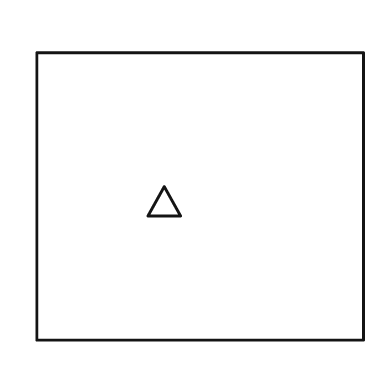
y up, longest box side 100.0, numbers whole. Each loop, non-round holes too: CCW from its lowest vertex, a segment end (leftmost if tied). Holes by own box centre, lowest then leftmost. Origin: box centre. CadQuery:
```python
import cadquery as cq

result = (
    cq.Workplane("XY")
    .moveTo(-50.0, -44.0)
    .lineTo(50.0, -44.0)
    .lineTo(50.0, 44.0)
    .lineTo(-50.0, 44.0)
    .close()
    .moveTo(-16.0, -6.0)
    .lineTo(-6.0, -6.0)
    .lineTo(-11.0, 3.0)
    .close()
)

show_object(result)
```